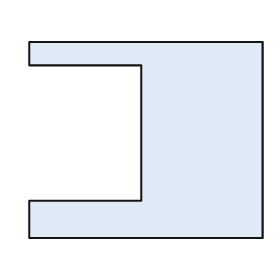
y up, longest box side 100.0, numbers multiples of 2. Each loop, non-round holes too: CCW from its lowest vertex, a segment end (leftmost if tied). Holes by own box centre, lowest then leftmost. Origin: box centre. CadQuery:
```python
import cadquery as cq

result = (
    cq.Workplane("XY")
    .moveTo(-50.0, -42.0)
    .lineTo(50.0, -42.0)
    .lineTo(50.0, 42.0)
    .lineTo(-50.0, 42.0)
    .lineTo(-50.0, 32.0)
    .lineTo(-2.0, 32.0)
    .lineTo(-2.0, -26.0)
    .lineTo(-50.0, -26.0)
    .close()
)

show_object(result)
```